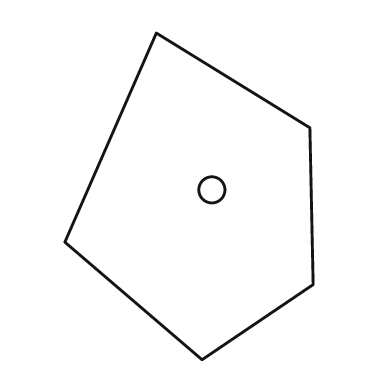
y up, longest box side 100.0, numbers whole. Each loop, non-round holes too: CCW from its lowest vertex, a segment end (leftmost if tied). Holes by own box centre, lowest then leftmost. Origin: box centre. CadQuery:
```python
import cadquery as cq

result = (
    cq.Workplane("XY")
    .moveTo(4.0, -50.0)
    .lineTo(38.0, -27.0)
    .lineTo(37.0, 21.0)
    .lineTo(-10.0, 50.0)
    .lineTo(-38.0, -14.0)
    .close()
    .moveTo(7.0, 2.0)
    .circle(4.0)
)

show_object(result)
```